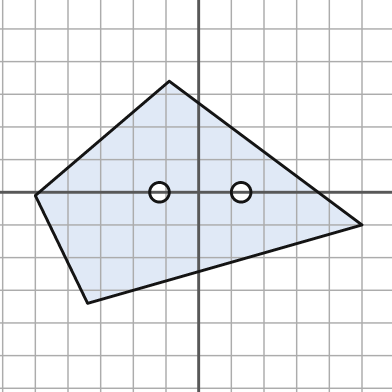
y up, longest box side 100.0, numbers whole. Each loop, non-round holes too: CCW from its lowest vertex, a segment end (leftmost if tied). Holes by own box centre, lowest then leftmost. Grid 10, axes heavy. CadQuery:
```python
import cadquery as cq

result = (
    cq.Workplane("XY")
    .moveTo(-34.0, -34.0)
    .lineTo(50.0, -10.0)
    .lineTo(-9.0, 34.0)
    .lineTo(-50.0, -1.0)
    .close()
    .moveTo(-12.0, 0.0)
    .circle(3.0)
    .moveTo(13.0, 0.0)
    .circle(3.0)
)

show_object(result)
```